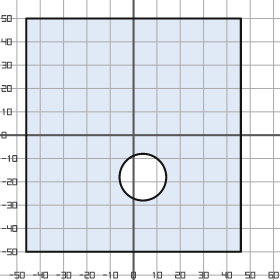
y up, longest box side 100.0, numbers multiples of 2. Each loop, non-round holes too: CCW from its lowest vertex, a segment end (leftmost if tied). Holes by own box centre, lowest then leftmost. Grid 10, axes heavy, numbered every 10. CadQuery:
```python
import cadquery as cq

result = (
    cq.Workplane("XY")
    .moveTo(-46.0, -50.0)
    .lineTo(46.0, -50.0)
    .lineTo(46.0, 50.0)
    .lineTo(-46.0, 50.0)
    .close()
    .moveTo(4.0, -18.0)
    .circle(10.0)
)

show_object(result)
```